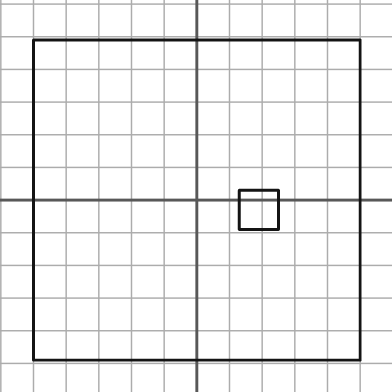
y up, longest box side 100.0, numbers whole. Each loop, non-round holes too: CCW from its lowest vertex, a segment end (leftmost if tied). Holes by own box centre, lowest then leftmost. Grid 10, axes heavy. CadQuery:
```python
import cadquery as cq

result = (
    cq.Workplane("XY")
    .moveTo(-50.0, -49.0)
    .lineTo(50.0, -49.0)
    .lineTo(50.0, 49.0)
    .lineTo(-50.0, 49.0)
    .close()
    .moveTo(13.0, -9.0)
    .lineTo(25.0, -9.0)
    .lineTo(25.0, 3.0)
    .lineTo(13.0, 3.0)
    .close()
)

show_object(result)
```